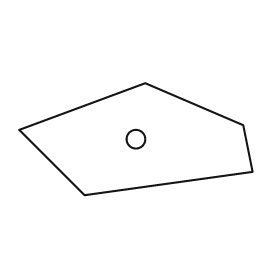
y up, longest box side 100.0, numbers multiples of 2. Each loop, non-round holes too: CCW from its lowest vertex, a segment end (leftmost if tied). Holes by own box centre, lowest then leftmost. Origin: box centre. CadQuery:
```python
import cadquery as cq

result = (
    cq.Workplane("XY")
    .moveTo(-22.0, -24.0)
    .lineTo(50.0, -14.0)
    .lineTo(46.0, 6.0)
    .lineTo(4.0, 24.0)
    .lineTo(-50.0, 4.0)
    .close()
    .moveTo(0.0, 0.0)
    .circle(4.0)
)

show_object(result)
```